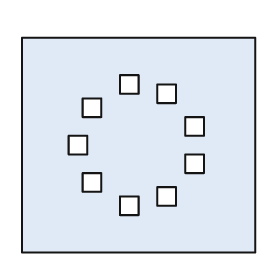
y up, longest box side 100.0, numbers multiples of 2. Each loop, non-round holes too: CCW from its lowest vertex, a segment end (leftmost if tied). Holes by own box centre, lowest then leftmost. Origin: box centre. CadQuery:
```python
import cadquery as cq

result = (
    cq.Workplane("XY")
    .moveTo(-50.0, -46.0)
    .lineTo(50.0, -46.0)
    .lineTo(50.0, 46.0)
    .lineTo(-50.0, 46.0)
    .close()
    .moveTo(-8.0, -30.0)
    .lineTo(0.0, -30.0)
    .lineTo(0.0, -22.0)
    .lineTo(-8.0, -22.0)
    .close()
    .moveTo(8.0, -26.0)
    .lineTo(16.0, -26.0)
    .lineTo(16.0, -18.0)
    .lineTo(8.0, -18.0)
    .close()
    .moveTo(-24.0, -20.0)
    .lineTo(-16.0, -20.0)
    .lineTo(-16.0, -12.0)
    .lineTo(-24.0, -12.0)
    .close()
    .moveTo(20.0, -12.0)
    .lineTo(28.0, -12.0)
    .lineTo(28.0, -4.0)
    .lineTo(20.0, -4.0)
    .close()
    .moveTo(-30.0, -4.0)
    .lineTo(-22.0, -4.0)
    .lineTo(-22.0, 4.0)
    .lineTo(-30.0, 4.0)
    .close()
    .moveTo(20.0, 4.0)
    .lineTo(28.0, 4.0)
    .lineTo(28.0, 12.0)
    .lineTo(20.0, 12.0)
    .close()
    .moveTo(-24.0, 12.0)
    .lineTo(-16.0, 12.0)
    .lineTo(-16.0, 20.0)
    .lineTo(-24.0, 20.0)
    .close()
    .moveTo(8.0, 18.0)
    .lineTo(16.0, 18.0)
    .lineTo(16.0, 26.0)
    .lineTo(8.0, 26.0)
    .close()
    .moveTo(-8.0, 22.0)
    .lineTo(0.0, 22.0)
    .lineTo(0.0, 30.0)
    .lineTo(-8.0, 30.0)
    .close()
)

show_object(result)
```